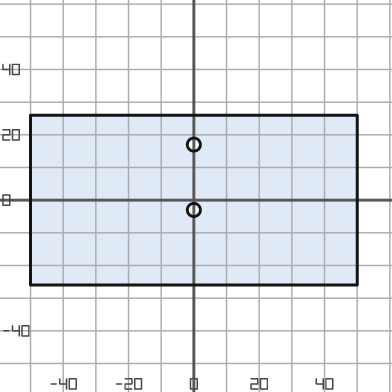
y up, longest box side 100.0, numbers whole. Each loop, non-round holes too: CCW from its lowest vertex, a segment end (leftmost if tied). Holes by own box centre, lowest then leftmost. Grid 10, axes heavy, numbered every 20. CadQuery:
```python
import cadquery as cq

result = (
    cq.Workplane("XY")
    .moveTo(-50.0, -26.0)
    .lineTo(50.0, -26.0)
    .lineTo(50.0, 26.0)
    .lineTo(-50.0, 26.0)
    .close()
    .moveTo(0.0, -3.0)
    .circle(2.0)
    .moveTo(0.0, 17.0)
    .circle(2.0)
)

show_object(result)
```